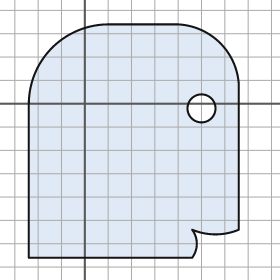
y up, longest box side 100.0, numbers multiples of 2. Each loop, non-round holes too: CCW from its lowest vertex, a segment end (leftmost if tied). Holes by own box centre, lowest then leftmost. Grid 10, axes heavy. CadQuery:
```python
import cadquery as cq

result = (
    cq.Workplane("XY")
    .moveTo(-24.0, -66.0)
    .lineTo(46.0, -66.0)
    .threePointArc((48.0, -60.0), (46.0, -54.0))
    .threePointArc((56.0, -56.0), (66.0, -54.0))
    .lineTo(66.0, 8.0)
    .threePointArc((58.0, 26.0), (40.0, 34.0))
    .lineTo(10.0, 34.0)
    .threePointArc((-14.0, 24.0), (-24.0, 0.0))
    .close()
    .moveTo(50.0, -2.0)
    .circle(6.0)
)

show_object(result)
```